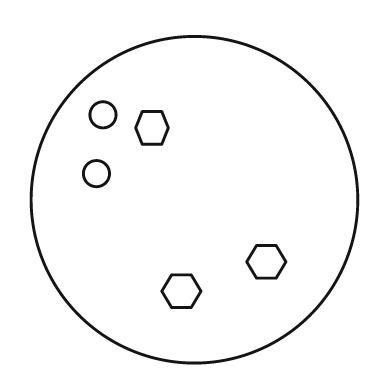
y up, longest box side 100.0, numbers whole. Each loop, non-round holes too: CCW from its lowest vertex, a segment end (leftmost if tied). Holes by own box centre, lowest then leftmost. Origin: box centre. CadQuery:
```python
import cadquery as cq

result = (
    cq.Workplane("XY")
    .moveTo(0.0, 0.0)
    .circle(50.0)
    .moveTo(-7.0, -33.0)
    .lineTo(-1.0, -33.0)
    .lineTo(2.0, -28.0)
    .lineTo(-1.0, -23.0)
    .lineTo(-7.0, -23.0)
    .lineTo(-10.0, -28.0)
    .close()
    .moveTo(19.0, -24.0)
    .lineTo(25.0, -24.0)
    .lineTo(28.0, -19.0)
    .lineTo(25.0, -14.0)
    .lineTo(19.0, -14.0)
    .lineTo(16.0, -19.0)
    .close()
    .moveTo(-30.0, 8.0)
    .circle(4.0)
    .moveTo(-16.0, 17.0)
    .lineTo(-10.0, 17.0)
    .lineTo(-8.0, 22.0)
    .lineTo(-10.0, 27.0)
    .lineTo(-16.0, 27.0)
    .lineTo(-18.0, 22.0)
    .close()
    .moveTo(-28.0, 26.0)
    .circle(4.0)
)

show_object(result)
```